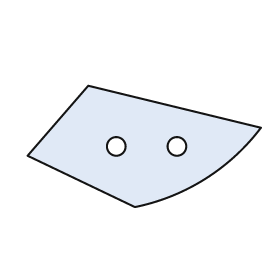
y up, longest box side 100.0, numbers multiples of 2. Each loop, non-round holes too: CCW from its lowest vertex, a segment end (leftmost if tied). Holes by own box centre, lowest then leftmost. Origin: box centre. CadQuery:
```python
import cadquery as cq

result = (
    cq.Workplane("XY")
    .moveTo(-4.0, -26.0)
    .threePointArc((26.0, -14.0), (50.0, 8.0))
    .lineTo(-24.0, 26.0)
    .lineTo(-50.0, -4.0)
    .close()
    .moveTo(-12.0, 0.0)
    .circle(4.0)
    .moveTo(14.0, 0.0)
    .circle(4.0)
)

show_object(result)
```